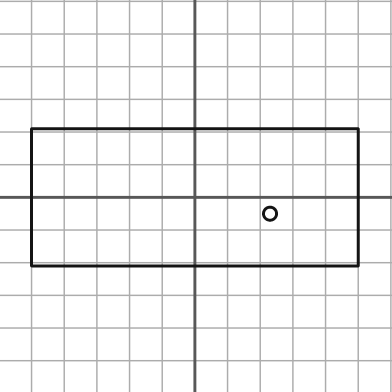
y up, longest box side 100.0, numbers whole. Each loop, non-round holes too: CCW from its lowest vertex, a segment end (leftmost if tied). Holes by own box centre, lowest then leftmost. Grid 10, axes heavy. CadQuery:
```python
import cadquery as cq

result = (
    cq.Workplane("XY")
    .moveTo(-50.0, -21.0)
    .lineTo(50.0, -21.0)
    .lineTo(50.0, 21.0)
    .lineTo(-50.0, 21.0)
    .close()
    .moveTo(23.0, -5.0)
    .circle(2.0)
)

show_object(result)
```